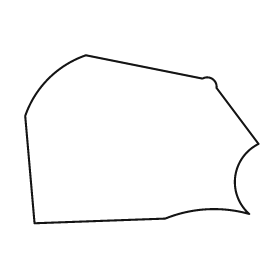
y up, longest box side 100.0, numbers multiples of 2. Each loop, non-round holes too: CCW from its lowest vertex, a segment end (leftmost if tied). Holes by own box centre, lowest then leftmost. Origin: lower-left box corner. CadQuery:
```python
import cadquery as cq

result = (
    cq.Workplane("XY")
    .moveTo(4.0, 0.0)
    .lineTo(60.0, 2.0)
    .threePointArc((78.0, 6.0), (96.0, 4.0))
    .threePointArc((90.0, 20.0), (100.0, 34.0))
    .lineTo(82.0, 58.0)
    .threePointArc((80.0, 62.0), (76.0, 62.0))
    .lineTo(26.0, 72.0)
    .threePointArc((10.0, 62.0), (0.0, 46.0))
    .close()
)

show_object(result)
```